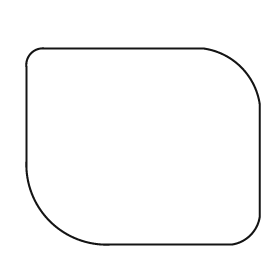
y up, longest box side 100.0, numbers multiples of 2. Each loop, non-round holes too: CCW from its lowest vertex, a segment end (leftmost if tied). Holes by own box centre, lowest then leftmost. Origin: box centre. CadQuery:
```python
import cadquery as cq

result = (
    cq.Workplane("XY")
    .moveTo(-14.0, -42.0)
    .lineTo(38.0, -42.0)
    .threePointArc((46.0, -38.0), (50.0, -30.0))
    .lineTo(50.0, 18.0)
    .threePointArc((42.0, 34.0), (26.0, 42.0))
    .lineTo(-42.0, 42.0)
    .threePointArc((-48.0, 40.0), (-50.0, 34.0))
    .lineTo(-50.0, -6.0)
    .threePointArc((-40.0, -32.0), (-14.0, -42.0))
    .close()
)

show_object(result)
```